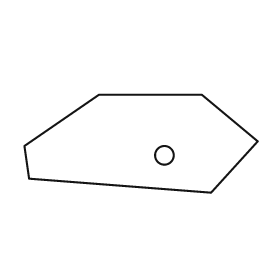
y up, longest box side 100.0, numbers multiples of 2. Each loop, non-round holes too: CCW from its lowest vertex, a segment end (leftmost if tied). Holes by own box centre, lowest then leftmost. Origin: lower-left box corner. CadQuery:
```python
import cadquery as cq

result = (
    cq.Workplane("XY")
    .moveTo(80.0, 0.0)
    .lineTo(100.0, 22.0)
    .lineTo(76.0, 42.0)
    .lineTo(32.0, 42.0)
    .lineTo(0.0, 20.0)
    .lineTo(2.0, 6.0)
    .close()
    .moveTo(60.0, 16.0)
    .circle(4.0)
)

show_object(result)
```